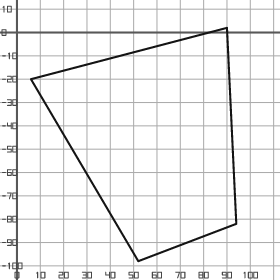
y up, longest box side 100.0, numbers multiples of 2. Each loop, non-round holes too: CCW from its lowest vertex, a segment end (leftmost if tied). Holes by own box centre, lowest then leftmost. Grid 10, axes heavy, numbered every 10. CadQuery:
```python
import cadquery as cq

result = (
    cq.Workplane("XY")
    .moveTo(52.0, -98.0)
    .lineTo(94.0, -82.0)
    .lineTo(90.0, 2.0)
    .lineTo(6.0, -20.0)
    .close()
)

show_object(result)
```